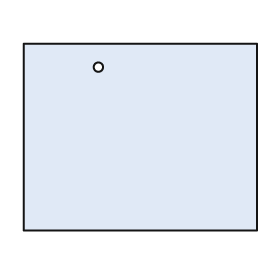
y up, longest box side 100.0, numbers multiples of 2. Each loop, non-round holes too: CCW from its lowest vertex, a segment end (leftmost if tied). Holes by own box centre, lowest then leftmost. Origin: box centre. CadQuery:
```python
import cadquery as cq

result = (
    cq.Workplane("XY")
    .moveTo(-50.0, -40.0)
    .lineTo(50.0, -40.0)
    .lineTo(50.0, 40.0)
    .lineTo(-50.0, 40.0)
    .close()
    .moveTo(-18.0, 30.0)
    .circle(2.0)
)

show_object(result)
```